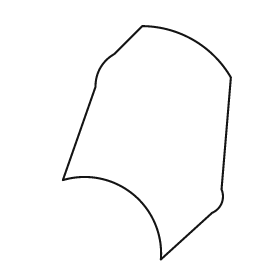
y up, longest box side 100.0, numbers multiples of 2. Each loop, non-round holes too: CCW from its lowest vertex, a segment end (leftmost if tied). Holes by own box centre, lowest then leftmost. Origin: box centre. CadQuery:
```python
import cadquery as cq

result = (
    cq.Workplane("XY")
    .moveTo(6.0, -50.0)
    .lineTo(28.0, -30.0)
    .threePointArc((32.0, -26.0), (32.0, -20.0))
    .lineTo(36.0, 28.0)
    .threePointArc((20.0, 44.0), (-2.0, 50.0))
    .lineTo(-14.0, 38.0)
    .threePointArc((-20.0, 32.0), (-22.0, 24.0))
    .lineTo(-36.0, -16.0)
    .threePointArc((-6.0, -22.0), (6.0, -50.0))
    .close()
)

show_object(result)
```